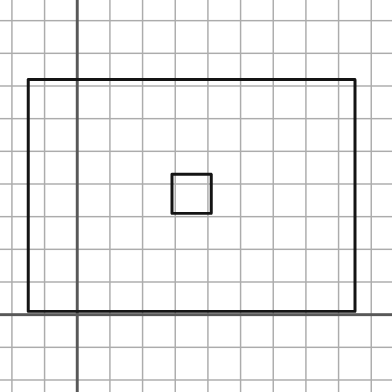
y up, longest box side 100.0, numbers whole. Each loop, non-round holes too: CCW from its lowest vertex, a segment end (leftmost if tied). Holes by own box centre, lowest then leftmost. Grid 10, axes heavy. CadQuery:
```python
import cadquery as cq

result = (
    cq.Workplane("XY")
    .moveTo(-15.0, 1.0)
    .lineTo(85.0, 1.0)
    .lineTo(85.0, 72.0)
    .lineTo(-15.0, 72.0)
    .close()
    .moveTo(29.0, 31.0)
    .lineTo(41.0, 31.0)
    .lineTo(41.0, 43.0)
    .lineTo(29.0, 43.0)
    .close()
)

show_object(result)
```